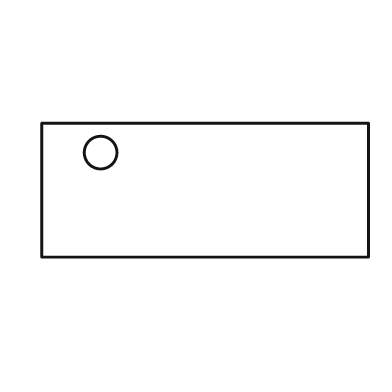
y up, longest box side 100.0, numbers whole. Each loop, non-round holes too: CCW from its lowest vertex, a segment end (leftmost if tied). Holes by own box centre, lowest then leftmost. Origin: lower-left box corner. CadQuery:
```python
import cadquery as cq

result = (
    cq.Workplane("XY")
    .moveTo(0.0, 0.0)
    .lineTo(100.0, 0.0)
    .lineTo(100.0, 41.0)
    .lineTo(0.0, 41.0)
    .close()
    .moveTo(18.0, 32.0)
    .circle(5.0)
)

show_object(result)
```